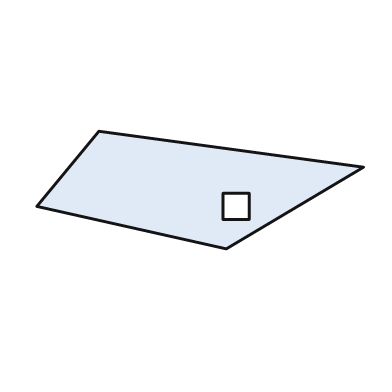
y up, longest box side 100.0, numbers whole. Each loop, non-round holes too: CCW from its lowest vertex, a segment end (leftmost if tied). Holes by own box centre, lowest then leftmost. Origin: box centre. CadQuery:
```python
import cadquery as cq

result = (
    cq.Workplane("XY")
    .moveTo(8.0, -18.0)
    .lineTo(50.0, 7.0)
    .lineTo(-31.0, 18.0)
    .lineTo(-50.0, -5.0)
    .close()
    .moveTo(7.0, -9.0)
    .lineTo(15.0, -9.0)
    .lineTo(15.0, -1.0)
    .lineTo(7.0, -1.0)
    .close()
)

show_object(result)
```